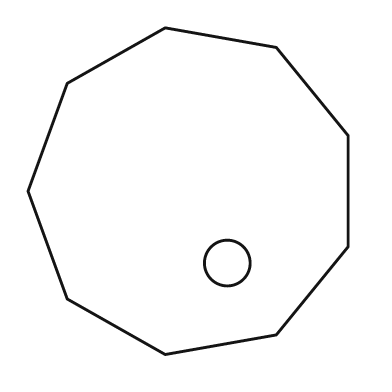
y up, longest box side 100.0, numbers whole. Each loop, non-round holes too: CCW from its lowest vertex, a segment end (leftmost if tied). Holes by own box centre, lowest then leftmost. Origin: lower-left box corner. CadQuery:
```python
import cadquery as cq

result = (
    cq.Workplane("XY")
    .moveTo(42.0, 0.0)
    .lineTo(76.0, 6.0)
    .lineTo(98.0, 33.0)
    .lineTo(98.0, 67.0)
    .lineTo(76.0, 94.0)
    .lineTo(42.0, 100.0)
    .lineTo(12.0, 83.0)
    .lineTo(0.0, 50.0)
    .lineTo(12.0, 17.0)
    .close()
    .moveTo(61.0, 28.0)
    .circle(7.0)
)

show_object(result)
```